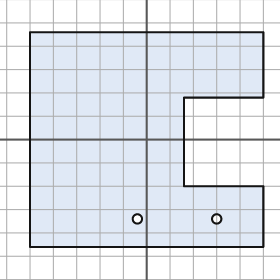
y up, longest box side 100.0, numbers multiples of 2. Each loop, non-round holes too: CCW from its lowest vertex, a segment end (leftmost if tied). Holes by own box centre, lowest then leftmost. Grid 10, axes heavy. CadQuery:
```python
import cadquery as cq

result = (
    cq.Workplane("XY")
    .moveTo(-50.0, -46.0)
    .lineTo(50.0, -46.0)
    .lineTo(50.0, -20.0)
    .lineTo(16.0, -20.0)
    .lineTo(16.0, 18.0)
    .lineTo(50.0, 18.0)
    .lineTo(50.0, 46.0)
    .lineTo(-50.0, 46.0)
    .close()
    .moveTo(-4.0, -34.0)
    .circle(2.0)
    .moveTo(30.0, -34.0)
    .circle(2.0)
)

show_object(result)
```